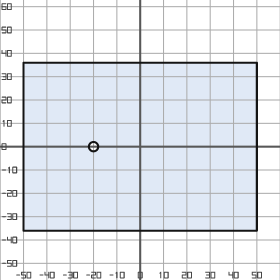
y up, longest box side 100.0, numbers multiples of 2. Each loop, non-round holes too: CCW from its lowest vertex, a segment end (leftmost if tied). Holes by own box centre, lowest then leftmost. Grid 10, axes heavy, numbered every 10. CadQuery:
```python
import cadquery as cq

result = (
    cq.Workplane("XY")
    .moveTo(-50.0, -36.0)
    .lineTo(50.0, -36.0)
    .lineTo(50.0, 36.0)
    .lineTo(-50.0, 36.0)
    .close()
    .moveTo(-20.0, 0.0)
    .circle(2.0)
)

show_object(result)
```